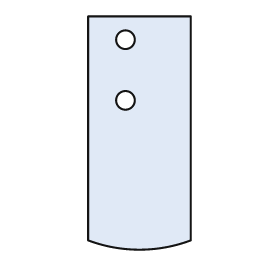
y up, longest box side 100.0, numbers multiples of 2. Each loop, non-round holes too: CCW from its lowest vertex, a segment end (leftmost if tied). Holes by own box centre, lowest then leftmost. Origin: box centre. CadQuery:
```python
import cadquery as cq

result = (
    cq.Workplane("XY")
    .moveTo(-22.0, -46.0)
    .threePointArc((0.0, -50.0), (22.0, -46.0))
    .lineTo(22.0, 50.0)
    .lineTo(-22.0, 50.0)
    .close()
    .moveTo(-6.0, 14.0)
    .circle(4.0)
    .moveTo(-6.0, 40.0)
    .circle(4.0)
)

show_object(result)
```